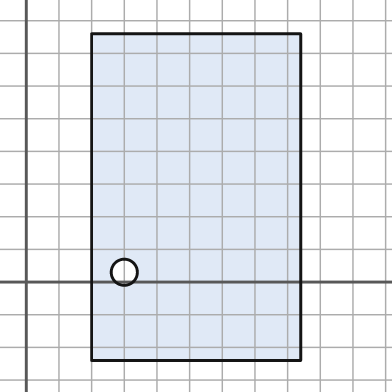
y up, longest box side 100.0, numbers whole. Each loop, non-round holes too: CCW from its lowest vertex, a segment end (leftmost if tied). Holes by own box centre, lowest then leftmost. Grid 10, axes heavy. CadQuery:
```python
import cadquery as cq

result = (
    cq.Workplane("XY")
    .moveTo(20.0, -24.0)
    .lineTo(84.0, -24.0)
    .lineTo(84.0, 76.0)
    .lineTo(20.0, 76.0)
    .close()
    .moveTo(30.0, 3.0)
    .circle(4.0)
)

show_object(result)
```